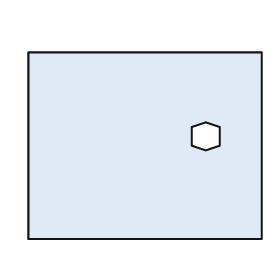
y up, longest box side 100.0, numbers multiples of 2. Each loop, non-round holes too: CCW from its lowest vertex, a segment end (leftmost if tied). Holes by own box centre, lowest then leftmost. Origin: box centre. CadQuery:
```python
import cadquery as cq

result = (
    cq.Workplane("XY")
    .moveTo(-50.0, -40.0)
    .lineTo(50.0, -40.0)
    .lineTo(50.0, 40.0)
    .lineTo(-50.0, 40.0)
    .close()
    .moveTo(26.0, -2.0)
    .lineTo(32.0, 0.0)
    .lineTo(32.0, 8.0)
    .lineTo(26.0, 10.0)
    .lineTo(20.0, 8.0)
    .lineTo(20.0, 0.0)
    .close()
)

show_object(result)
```